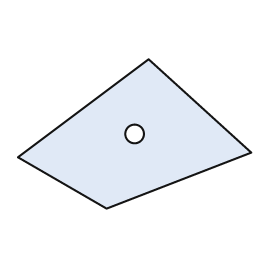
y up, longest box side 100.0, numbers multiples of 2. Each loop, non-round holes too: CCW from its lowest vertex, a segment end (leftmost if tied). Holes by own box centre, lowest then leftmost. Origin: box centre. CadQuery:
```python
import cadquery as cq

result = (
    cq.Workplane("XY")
    .moveTo(-12.0, -32.0)
    .lineTo(50.0, -8.0)
    .lineTo(6.0, 32.0)
    .lineTo(-50.0, -10.0)
    .close()
    .moveTo(0.0, 0.0)
    .circle(4.0)
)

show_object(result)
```